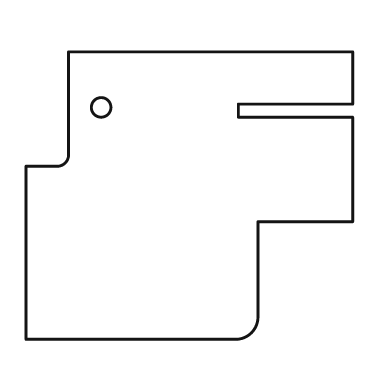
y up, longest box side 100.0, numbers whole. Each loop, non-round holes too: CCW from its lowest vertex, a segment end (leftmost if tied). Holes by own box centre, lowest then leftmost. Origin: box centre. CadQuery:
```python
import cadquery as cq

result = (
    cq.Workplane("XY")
    .moveTo(-50.0, -44.0)
    .lineTo(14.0, -44.0)
    .threePointArc((19.0, -42.0), (21.0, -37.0))
    .lineTo(21.0, -8.0)
    .lineTo(50.0, -8.0)
    .lineTo(50.0, 24.0)
    .lineTo(15.0, 24.0)
    .lineTo(15.0, 28.0)
    .lineTo(50.0, 28.0)
    .lineTo(50.0, 44.0)
    .lineTo(-37.0, 44.0)
    .lineTo(-37.0, 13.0)
    .threePointArc((-38.0, 10.0), (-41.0, 9.0))
    .lineTo(-50.0, 9.0)
    .close()
    .moveTo(-27.0, 27.0)
    .circle(3.0)
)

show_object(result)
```